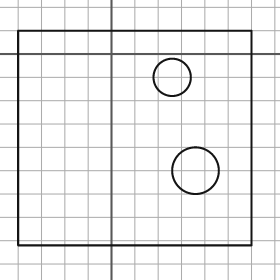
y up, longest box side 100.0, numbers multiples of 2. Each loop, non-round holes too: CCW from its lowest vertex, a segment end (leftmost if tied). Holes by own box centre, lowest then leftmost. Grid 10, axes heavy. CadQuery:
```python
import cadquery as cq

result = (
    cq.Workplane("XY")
    .moveTo(-40.0, -82.0)
    .lineTo(60.0, -82.0)
    .lineTo(60.0, 10.0)
    .lineTo(-40.0, 10.0)
    .close()
    .moveTo(36.0, -50.0)
    .circle(10.0)
    .moveTo(26.0, -10.0)
    .circle(8.0)
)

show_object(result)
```